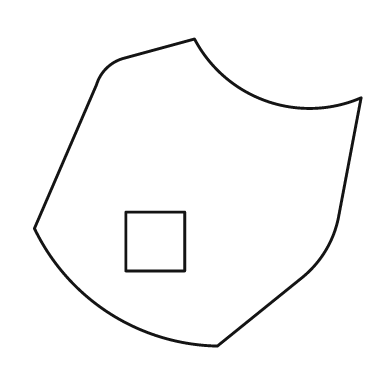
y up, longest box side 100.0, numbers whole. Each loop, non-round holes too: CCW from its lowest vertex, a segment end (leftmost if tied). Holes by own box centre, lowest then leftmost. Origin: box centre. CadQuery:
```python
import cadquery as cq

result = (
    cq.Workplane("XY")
    .moveTo(6.0, -47.0)
    .lineTo(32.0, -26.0)
    .threePointArc((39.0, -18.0), (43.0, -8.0))
    .lineTo(50.0, 29.0)
    .threePointArc((21.0, 28.0), (-1.0, 47.0))
    .lineTo(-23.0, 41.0)
    .threePointArc((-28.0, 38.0), (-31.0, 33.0))
    .lineTo(-50.0, -11.0)
    .threePointArc((-27.0, -37.0), (6.0, -47.0))
    .close()
    .moveTo(-22.0, -24.0)
    .lineTo(-4.0, -24.0)
    .lineTo(-4.0, -6.0)
    .lineTo(-22.0, -6.0)
    .close()
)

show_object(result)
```